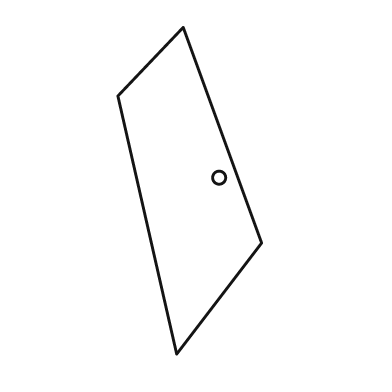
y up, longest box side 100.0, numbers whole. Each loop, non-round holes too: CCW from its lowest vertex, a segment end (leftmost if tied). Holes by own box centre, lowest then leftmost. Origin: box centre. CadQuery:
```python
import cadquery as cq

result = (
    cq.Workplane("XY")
    .moveTo(-4.0, -50.0)
    .lineTo(22.0, -16.0)
    .lineTo(-2.0, 50.0)
    .lineTo(-22.0, 29.0)
    .close()
    .moveTo(9.0, 4.0)
    .circle(2.0)
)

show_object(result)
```